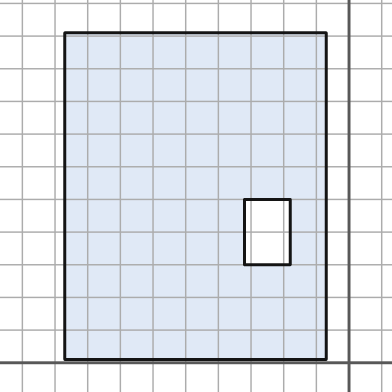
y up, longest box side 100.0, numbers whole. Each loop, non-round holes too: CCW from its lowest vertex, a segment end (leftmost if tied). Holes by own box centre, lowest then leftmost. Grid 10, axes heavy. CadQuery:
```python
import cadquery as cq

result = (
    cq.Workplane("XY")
    .moveTo(-87.0, 1.0)
    .lineTo(-7.0, 1.0)
    .lineTo(-7.0, 101.0)
    .lineTo(-87.0, 101.0)
    .close()
    .moveTo(-32.0, 30.0)
    .lineTo(-18.0, 30.0)
    .lineTo(-18.0, 50.0)
    .lineTo(-32.0, 50.0)
    .close()
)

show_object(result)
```